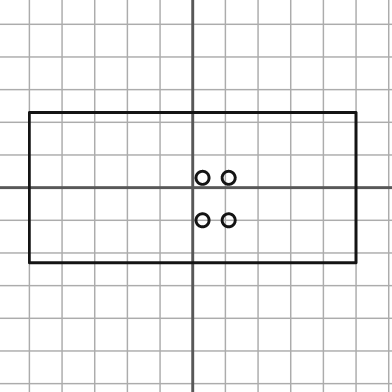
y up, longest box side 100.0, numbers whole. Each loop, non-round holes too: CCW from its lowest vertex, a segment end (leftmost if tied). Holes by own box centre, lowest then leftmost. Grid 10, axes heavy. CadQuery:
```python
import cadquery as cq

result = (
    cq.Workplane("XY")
    .moveTo(-50.0, -23.0)
    .lineTo(50.0, -23.0)
    .lineTo(50.0, 23.0)
    .lineTo(-50.0, 23.0)
    .close()
    .moveTo(3.0, -10.0)
    .circle(2.0)
    .moveTo(11.0, -10.0)
    .circle(2.0)
    .moveTo(3.0, 3.0)
    .circle(2.0)
    .moveTo(11.0, 3.0)
    .circle(2.0)
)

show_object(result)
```